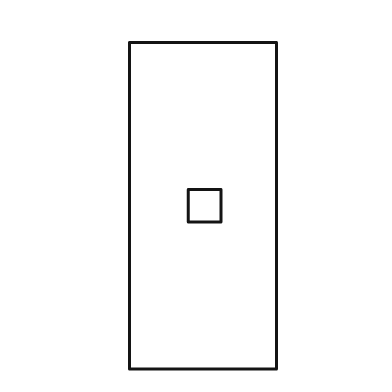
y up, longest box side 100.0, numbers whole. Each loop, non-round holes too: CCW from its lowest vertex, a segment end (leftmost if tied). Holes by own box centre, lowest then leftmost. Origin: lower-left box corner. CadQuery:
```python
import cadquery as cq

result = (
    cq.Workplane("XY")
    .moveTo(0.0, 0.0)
    .lineTo(45.0, 0.0)
    .lineTo(45.0, 100.0)
    .lineTo(0.0, 100.0)
    .close()
    .moveTo(18.0, 45.0)
    .lineTo(28.0, 45.0)
    .lineTo(28.0, 55.0)
    .lineTo(18.0, 55.0)
    .close()
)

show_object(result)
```